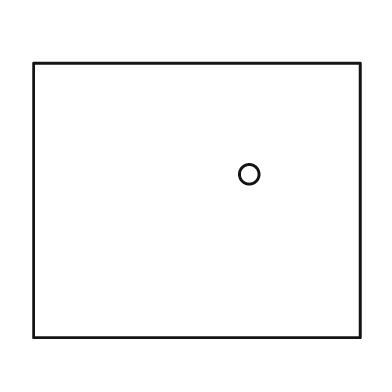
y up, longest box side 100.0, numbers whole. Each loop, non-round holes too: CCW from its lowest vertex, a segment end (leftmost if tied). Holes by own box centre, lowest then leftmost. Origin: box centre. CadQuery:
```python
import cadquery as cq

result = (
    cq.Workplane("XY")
    .moveTo(-50.0, -42.0)
    .lineTo(50.0, -42.0)
    .lineTo(50.0, 42.0)
    .lineTo(-50.0, 42.0)
    .close()
    .moveTo(16.0, 8.0)
    .circle(3.0)
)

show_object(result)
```